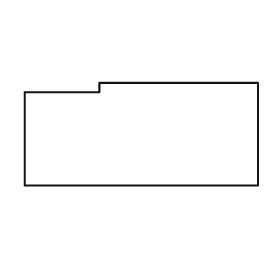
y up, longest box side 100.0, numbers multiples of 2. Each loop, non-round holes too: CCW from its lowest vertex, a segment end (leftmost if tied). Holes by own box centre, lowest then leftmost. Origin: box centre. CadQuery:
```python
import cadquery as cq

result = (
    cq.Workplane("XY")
    .moveTo(-50.0, -22.0)
    .lineTo(50.0, -22.0)
    .lineTo(50.0, 22.0)
    .lineTo(-18.0, 22.0)
    .lineTo(-18.0, 18.0)
    .lineTo(-50.0, 18.0)
    .close()
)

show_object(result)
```